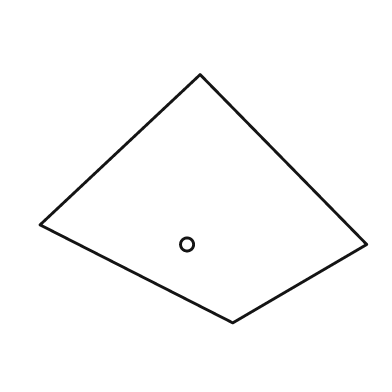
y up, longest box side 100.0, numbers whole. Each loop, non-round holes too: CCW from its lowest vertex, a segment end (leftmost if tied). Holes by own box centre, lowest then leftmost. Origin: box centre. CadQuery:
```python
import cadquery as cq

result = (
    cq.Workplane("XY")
    .moveTo(9.0, -38.0)
    .lineTo(50.0, -14.0)
    .lineTo(-1.0, 38.0)
    .lineTo(-50.0, -8.0)
    .close()
    .moveTo(-5.0, -14.0)
    .circle(2.0)
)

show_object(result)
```